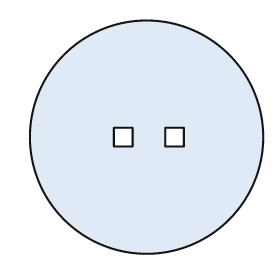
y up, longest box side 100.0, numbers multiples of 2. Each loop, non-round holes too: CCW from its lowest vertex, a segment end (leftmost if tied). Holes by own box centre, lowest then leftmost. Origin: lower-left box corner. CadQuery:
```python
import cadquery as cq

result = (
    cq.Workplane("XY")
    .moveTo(50.0, 50.0)
    .circle(50.0)
    .moveTo(36.0, 46.0)
    .lineTo(44.0, 46.0)
    .lineTo(44.0, 54.0)
    .lineTo(36.0, 54.0)
    .close()
    .moveTo(58.0, 46.0)
    .lineTo(66.0, 46.0)
    .lineTo(66.0, 54.0)
    .lineTo(58.0, 54.0)
    .close()
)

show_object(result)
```